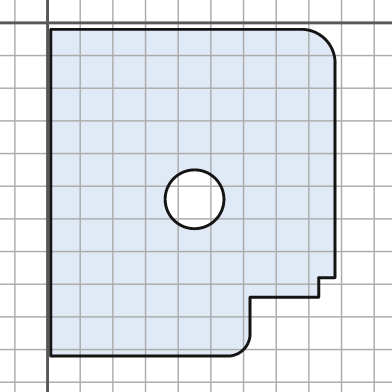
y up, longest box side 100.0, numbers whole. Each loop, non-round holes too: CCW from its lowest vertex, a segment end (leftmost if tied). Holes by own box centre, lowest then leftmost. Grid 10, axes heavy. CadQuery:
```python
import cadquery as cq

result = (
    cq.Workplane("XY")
    .moveTo(1.0, -102.0)
    .lineTo(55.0, -102.0)
    .threePointArc((60.0, -100.0), (62.0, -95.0))
    .lineTo(62.0, -84.0)
    .lineTo(83.0, -84.0)
    .lineTo(83.0, -78.0)
    .lineTo(88.0, -78.0)
    .lineTo(88.0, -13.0)
    .threePointArc((85.0, -5.0), (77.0, -2.0))
    .lineTo(1.0, -2.0)
    .close()
    .moveTo(45.0, -54.0)
    .circle(9.0)
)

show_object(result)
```